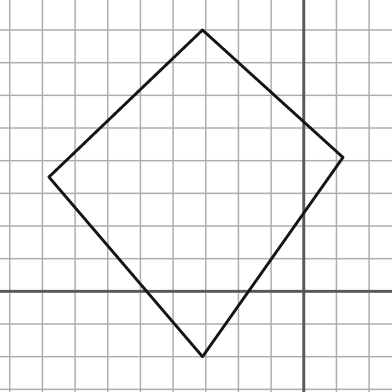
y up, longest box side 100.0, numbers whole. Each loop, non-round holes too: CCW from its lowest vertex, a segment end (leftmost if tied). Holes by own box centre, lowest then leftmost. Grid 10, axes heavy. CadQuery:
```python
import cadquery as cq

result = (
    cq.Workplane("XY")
    .moveTo(-31.0, -20.0)
    .lineTo(12.0, 41.0)
    .lineTo(-31.0, 80.0)
    .lineTo(-78.0, 35.0)
    .close()
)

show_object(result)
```